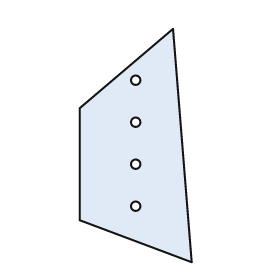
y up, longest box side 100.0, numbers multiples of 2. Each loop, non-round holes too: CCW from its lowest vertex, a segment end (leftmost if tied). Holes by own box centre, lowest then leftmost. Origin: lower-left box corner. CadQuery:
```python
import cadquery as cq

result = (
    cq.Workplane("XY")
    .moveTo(48.0, 0.0)
    .lineTo(40.0, 100.0)
    .lineTo(0.0, 66.0)
    .lineTo(0.0, 18.0)
    .close()
    .moveTo(24.0, 24.0)
    .circle(2.0)
    .moveTo(24.0, 42.0)
    .circle(2.0)
    .moveTo(24.0, 60.0)
    .circle(2.0)
    .moveTo(24.0, 78.0)
    .circle(2.0)
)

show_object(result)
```